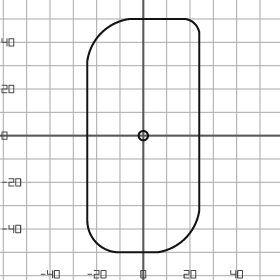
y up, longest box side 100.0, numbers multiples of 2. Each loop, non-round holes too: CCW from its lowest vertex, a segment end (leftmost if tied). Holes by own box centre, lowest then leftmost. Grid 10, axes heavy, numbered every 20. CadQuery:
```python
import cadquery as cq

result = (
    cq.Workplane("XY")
    .moveTo(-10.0, -50.0)
    .lineTo(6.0, -50.0)
    .threePointArc((18.0, -44.0), (24.0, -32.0))
    .lineTo(24.0, 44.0)
    .threePointArc((22.0, 48.0), (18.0, 50.0))
    .lineTo(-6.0, 50.0)
    .threePointArc((-18.0, 44.0), (-24.0, 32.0))
    .lineTo(-24.0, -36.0)
    .threePointArc((-20.0, -46.0), (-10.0, -50.0))
    .close()
    .moveTo(0.0, 0.0)
    .circle(2.0)
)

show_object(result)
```